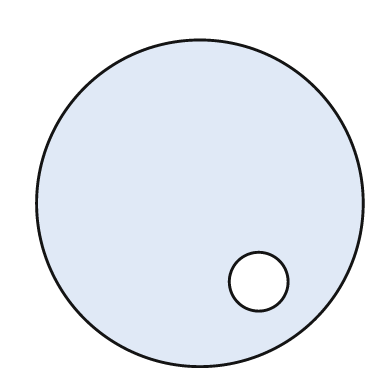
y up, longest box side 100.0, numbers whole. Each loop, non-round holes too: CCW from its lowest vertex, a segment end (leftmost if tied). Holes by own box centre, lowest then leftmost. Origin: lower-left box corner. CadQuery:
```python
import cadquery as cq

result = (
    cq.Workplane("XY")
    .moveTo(50.0, 50.0)
    .circle(50.0)
    .moveTo(68.0, 26.0)
    .circle(9.0)
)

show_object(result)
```